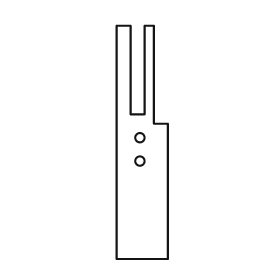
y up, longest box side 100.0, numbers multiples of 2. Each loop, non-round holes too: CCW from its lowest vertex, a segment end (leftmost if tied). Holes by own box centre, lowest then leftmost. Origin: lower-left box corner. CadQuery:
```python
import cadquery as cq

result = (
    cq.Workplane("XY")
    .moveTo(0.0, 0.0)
    .lineTo(22.0, 0.0)
    .lineTo(22.0, 58.0)
    .lineTo(16.0, 58.0)
    .lineTo(16.0, 100.0)
    .lineTo(12.0, 100.0)
    .lineTo(12.0, 62.0)
    .lineTo(6.0, 62.0)
    .lineTo(6.0, 100.0)
    .lineTo(0.0, 100.0)
    .close()
    .moveTo(10.0, 42.0)
    .circle(2.0)
    .moveTo(10.0, 52.0)
    .circle(2.0)
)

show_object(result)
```